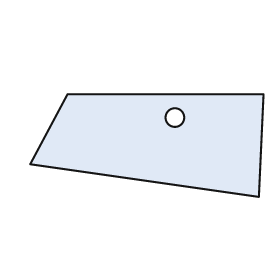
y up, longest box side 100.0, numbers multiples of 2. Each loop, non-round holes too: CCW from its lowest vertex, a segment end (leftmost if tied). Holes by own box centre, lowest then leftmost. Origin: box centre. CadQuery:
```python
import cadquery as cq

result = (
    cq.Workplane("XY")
    .moveTo(48.0, -22.0)
    .lineTo(50.0, 22.0)
    .lineTo(-34.0, 22.0)
    .lineTo(-50.0, -8.0)
    .close()
    .moveTo(12.0, 12.0)
    .circle(4.0)
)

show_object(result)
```